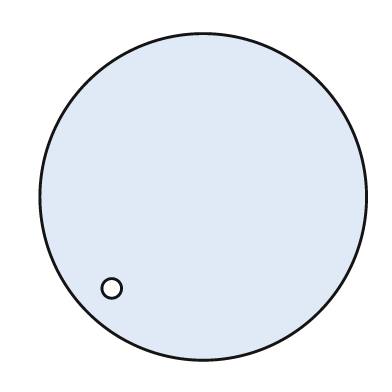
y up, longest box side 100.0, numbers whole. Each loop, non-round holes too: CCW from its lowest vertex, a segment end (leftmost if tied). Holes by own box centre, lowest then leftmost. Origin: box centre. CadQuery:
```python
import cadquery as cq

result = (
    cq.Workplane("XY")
    .moveTo(0.0, 0.0)
    .circle(50.0)
    .moveTo(-28.0, -28.0)
    .circle(3.0)
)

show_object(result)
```